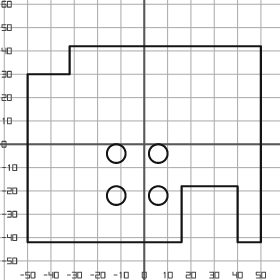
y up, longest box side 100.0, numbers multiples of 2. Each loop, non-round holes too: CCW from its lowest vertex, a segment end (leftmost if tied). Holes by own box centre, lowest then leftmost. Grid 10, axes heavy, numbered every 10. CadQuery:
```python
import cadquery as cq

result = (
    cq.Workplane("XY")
    .moveTo(-50.0, -42.0)
    .lineTo(16.0, -42.0)
    .lineTo(16.0, -18.0)
    .lineTo(40.0, -18.0)
    .lineTo(40.0, -42.0)
    .lineTo(50.0, -42.0)
    .lineTo(50.0, 42.0)
    .lineTo(-32.0, 42.0)
    .lineTo(-32.0, 30.0)
    .lineTo(-50.0, 30.0)
    .close()
    .moveTo(-12.0, -22.0)
    .circle(4.0)
    .moveTo(6.0, -22.0)
    .circle(4.0)
    .moveTo(-12.0, -4.0)
    .circle(4.0)
    .moveTo(6.0, -4.0)
    .circle(4.0)
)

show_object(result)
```